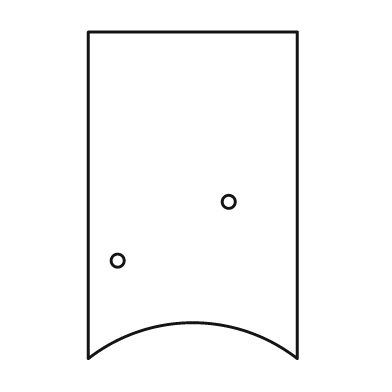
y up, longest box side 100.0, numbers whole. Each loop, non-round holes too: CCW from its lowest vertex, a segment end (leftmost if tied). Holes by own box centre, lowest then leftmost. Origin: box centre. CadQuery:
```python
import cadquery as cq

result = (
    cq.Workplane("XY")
    .moveTo(-32.0, -50.0)
    .threePointArc((0.0, -39.0), (32.0, -50.0))
    .lineTo(32.0, 50.0)
    .lineTo(-32.0, 50.0)
    .close()
    .moveTo(-23.0, -20.0)
    .circle(2.0)
    .moveTo(11.0, -2.0)
    .circle(2.0)
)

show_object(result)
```